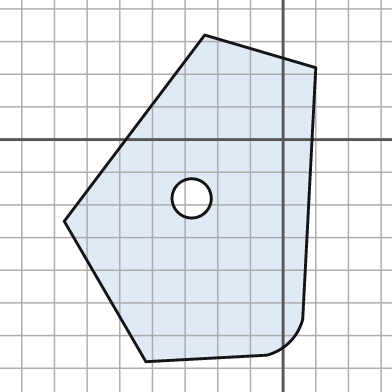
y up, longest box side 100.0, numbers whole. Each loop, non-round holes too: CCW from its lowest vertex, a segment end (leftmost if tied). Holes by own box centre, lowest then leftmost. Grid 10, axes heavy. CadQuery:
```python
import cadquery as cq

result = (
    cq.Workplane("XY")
    .moveTo(-42.0, -68.0)
    .lineTo(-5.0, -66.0)
    .threePointArc((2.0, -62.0), (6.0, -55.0))
    .lineTo(10.0, 22.0)
    .lineTo(-24.0, 32.0)
    .lineTo(-67.0, -25.0)
    .close()
    .moveTo(-28.0, -18.0)
    .circle(6.0)
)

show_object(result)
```